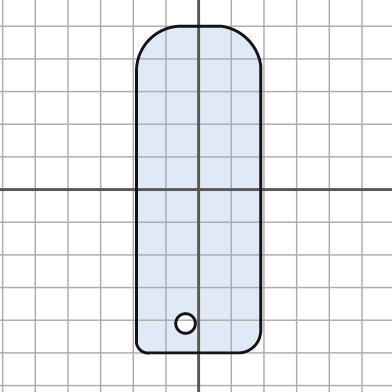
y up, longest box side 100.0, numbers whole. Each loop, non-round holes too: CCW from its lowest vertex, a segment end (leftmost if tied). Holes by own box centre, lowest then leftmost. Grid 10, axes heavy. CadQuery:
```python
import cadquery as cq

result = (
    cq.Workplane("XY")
    .moveTo(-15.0, -50.0)
    .lineTo(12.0, -50.0)
    .threePointArc((17.0, -48.0), (19.0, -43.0))
    .lineTo(19.0, 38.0)
    .threePointArc((15.0, 46.0), (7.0, 50.0))
    .lineTo(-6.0, 50.0)
    .threePointArc((-15.0, 46.0), (-19.0, 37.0))
    .lineTo(-19.0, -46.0)
    .threePointArc((-18.0, -49.0), (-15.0, -50.0))
    .close()
    .moveTo(-4.0, -41.0)
    .circle(3.0)
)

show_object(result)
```